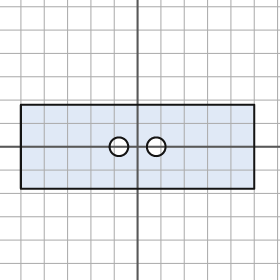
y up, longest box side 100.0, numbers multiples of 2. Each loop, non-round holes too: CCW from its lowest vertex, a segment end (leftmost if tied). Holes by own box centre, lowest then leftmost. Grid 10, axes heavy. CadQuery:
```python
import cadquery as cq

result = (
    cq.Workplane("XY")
    .moveTo(-50.0, -18.0)
    .lineTo(50.0, -18.0)
    .lineTo(50.0, 18.0)
    .lineTo(-50.0, 18.0)
    .close()
    .moveTo(-8.0, 0.0)
    .circle(4.0)
    .moveTo(8.0, 0.0)
    .circle(4.0)
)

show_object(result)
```